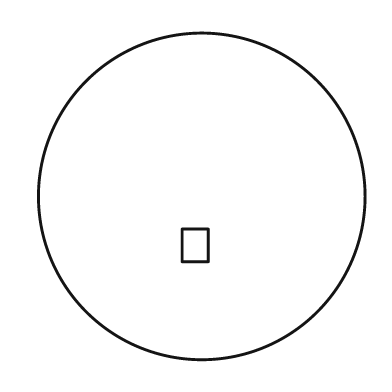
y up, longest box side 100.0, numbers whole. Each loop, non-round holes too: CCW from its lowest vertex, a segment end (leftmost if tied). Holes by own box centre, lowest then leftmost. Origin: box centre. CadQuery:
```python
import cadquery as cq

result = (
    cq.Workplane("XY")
    .moveTo(0.0, 0.0)
    .circle(50.0)
    .moveTo(-6.0, -20.0)
    .lineTo(2.0, -20.0)
    .lineTo(2.0, -10.0)
    .lineTo(-6.0, -10.0)
    .close()
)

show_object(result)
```